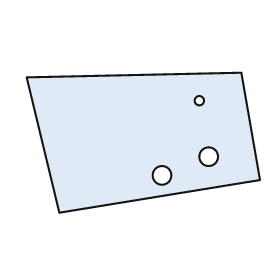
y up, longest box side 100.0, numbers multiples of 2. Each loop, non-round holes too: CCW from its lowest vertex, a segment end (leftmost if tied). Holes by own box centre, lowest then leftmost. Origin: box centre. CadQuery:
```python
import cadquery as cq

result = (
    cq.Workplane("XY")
    .moveTo(-36.0, -30.0)
    .lineTo(50.0, -16.0)
    .lineTo(42.0, 30.0)
    .lineTo(-50.0, 28.0)
    .close()
    .moveTo(8.0, -14.0)
    .circle(4.0)
    .moveTo(28.0, -6.0)
    .circle(4.0)
    .moveTo(24.0, 18.0)
    .circle(2.0)
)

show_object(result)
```